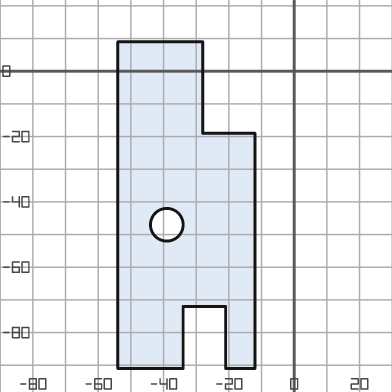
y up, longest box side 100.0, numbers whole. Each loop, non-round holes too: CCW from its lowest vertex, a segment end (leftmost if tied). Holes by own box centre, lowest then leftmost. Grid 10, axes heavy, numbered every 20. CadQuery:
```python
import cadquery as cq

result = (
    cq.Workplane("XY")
    .moveTo(-54.0, -91.0)
    .lineTo(-34.0, -91.0)
    .lineTo(-34.0, -72.0)
    .lineTo(-21.0, -72.0)
    .lineTo(-21.0, -91.0)
    .lineTo(-12.0, -91.0)
    .lineTo(-12.0, -19.0)
    .lineTo(-28.0, -19.0)
    .lineTo(-28.0, 9.0)
    .lineTo(-54.0, 9.0)
    .close()
    .moveTo(-39.0, -47.0)
    .circle(5.0)
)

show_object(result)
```